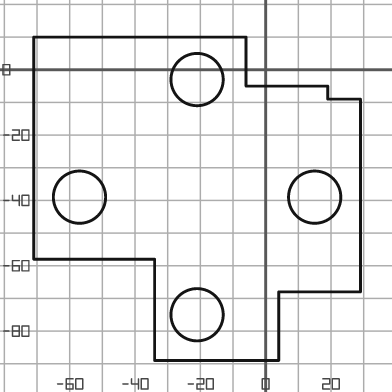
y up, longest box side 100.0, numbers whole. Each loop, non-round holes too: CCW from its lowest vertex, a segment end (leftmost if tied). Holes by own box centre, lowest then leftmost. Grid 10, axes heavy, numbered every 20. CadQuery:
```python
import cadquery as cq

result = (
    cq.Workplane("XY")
    .moveTo(-34.0, -89.0)
    .lineTo(4.0, -89.0)
    .lineTo(4.0, -68.0)
    .lineTo(29.0, -68.0)
    .lineTo(29.0, -9.0)
    .lineTo(19.0, -9.0)
    .lineTo(19.0, -5.0)
    .lineTo(-6.0, -5.0)
    .lineTo(-6.0, 10.0)
    .lineTo(-71.0, 10.0)
    .lineTo(-71.0, -58.0)
    .lineTo(-34.0, -58.0)
    .close()
    .moveTo(-21.0, -75.0)
    .circle(8.0)
    .moveTo(-57.0, -39.0)
    .circle(8.0)
    .moveTo(15.0, -39.0)
    .circle(8.0)
    .moveTo(-21.0, -3.0)
    .circle(8.0)
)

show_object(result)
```